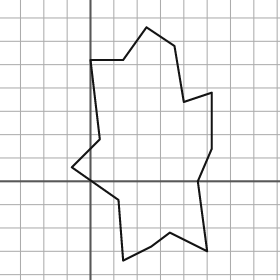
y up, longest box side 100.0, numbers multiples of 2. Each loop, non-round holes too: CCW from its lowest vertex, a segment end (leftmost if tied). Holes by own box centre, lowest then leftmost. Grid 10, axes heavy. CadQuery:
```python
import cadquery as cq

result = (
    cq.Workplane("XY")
    .moveTo(14.0, -34.0)
    .lineTo(26.0, -28.0)
    .lineTo(34.0, -22.0)
    .lineTo(50.0, -30.0)
    .lineTo(46.0, 0.0)
    .lineTo(52.0, 14.0)
    .lineTo(52.0, 38.0)
    .lineTo(40.0, 34.0)
    .lineTo(36.0, 58.0)
    .lineTo(24.0, 66.0)
    .lineTo(14.0, 52.0)
    .lineTo(0.0, 52.0)
    .lineTo(4.0, 18.0)
    .lineTo(-8.0, 6.0)
    .lineTo(12.0, -8.0)
    .close()
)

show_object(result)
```